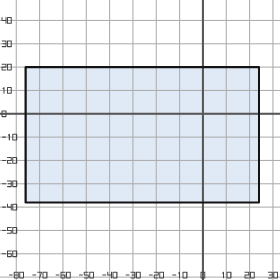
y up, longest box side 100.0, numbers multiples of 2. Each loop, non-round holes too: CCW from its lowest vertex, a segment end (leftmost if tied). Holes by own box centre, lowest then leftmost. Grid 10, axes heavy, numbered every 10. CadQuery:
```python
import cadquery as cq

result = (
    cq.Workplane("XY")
    .moveTo(-76.0, -38.0)
    .lineTo(24.0, -38.0)
    .lineTo(24.0, 20.0)
    .lineTo(-76.0, 20.0)
    .close()
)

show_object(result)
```